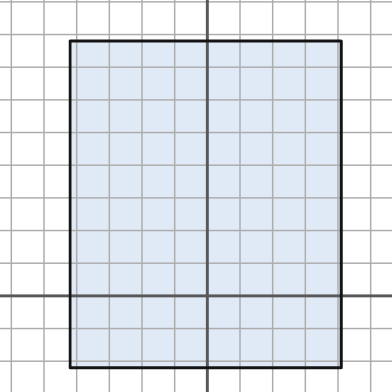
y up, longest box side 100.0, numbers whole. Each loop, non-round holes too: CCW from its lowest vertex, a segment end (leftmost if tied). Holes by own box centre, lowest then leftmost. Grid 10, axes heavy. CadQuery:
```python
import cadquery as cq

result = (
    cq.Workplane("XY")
    .moveTo(-42.0, -22.0)
    .lineTo(41.0, -22.0)
    .lineTo(41.0, 78.0)
    .lineTo(-42.0, 78.0)
    .close()
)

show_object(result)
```